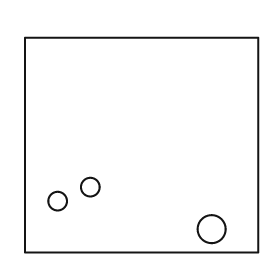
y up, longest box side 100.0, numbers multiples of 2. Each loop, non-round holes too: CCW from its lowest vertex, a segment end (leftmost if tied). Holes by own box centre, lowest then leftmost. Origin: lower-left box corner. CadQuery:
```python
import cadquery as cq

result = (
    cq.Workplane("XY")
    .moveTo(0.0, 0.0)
    .lineTo(100.0, 0.0)
    .lineTo(100.0, 92.0)
    .lineTo(0.0, 92.0)
    .close()
    .moveTo(80.0, 10.0)
    .circle(6.0)
    .moveTo(14.0, 22.0)
    .circle(4.0)
    .moveTo(28.0, 28.0)
    .circle(4.0)
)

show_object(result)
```